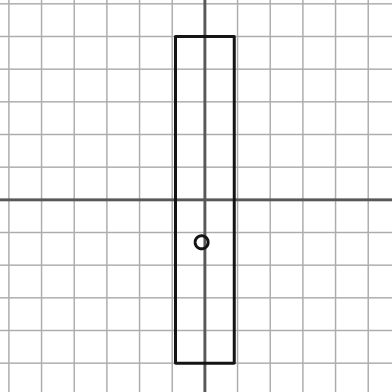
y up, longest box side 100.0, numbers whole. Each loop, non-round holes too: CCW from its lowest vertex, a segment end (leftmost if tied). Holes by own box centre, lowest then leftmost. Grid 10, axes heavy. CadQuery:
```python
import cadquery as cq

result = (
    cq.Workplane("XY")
    .moveTo(-9.0, -50.0)
    .lineTo(9.0, -50.0)
    .lineTo(9.0, 50.0)
    .lineTo(-9.0, 50.0)
    .close()
    .moveTo(-1.0, -13.0)
    .circle(2.0)
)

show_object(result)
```